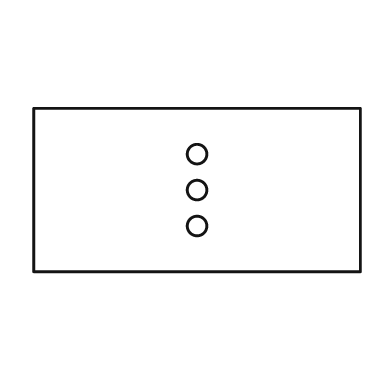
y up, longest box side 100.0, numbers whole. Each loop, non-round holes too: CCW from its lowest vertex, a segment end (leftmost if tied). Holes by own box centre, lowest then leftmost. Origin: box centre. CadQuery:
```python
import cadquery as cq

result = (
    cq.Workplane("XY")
    .moveTo(-50.0, -25.0)
    .lineTo(50.0, -25.0)
    .lineTo(50.0, 25.0)
    .lineTo(-50.0, 25.0)
    .close()
    .moveTo(0.0, -11.0)
    .circle(3.0)
    .moveTo(0.0, 0.0)
    .circle(3.0)
    .moveTo(0.0, 11.0)
    .circle(3.0)
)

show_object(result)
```